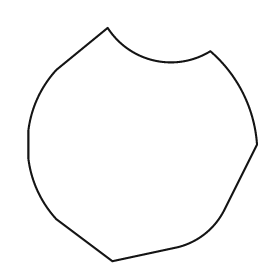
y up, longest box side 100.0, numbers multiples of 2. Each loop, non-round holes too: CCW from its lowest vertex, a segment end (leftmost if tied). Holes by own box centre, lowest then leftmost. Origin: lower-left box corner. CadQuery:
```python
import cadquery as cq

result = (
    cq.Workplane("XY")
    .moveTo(36.0, 0.0)
    .lineTo(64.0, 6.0)
    .threePointArc((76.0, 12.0), (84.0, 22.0))
    .lineTo(98.0, 50.0)
    .threePointArc((92.0, 72.0), (78.0, 90.0))
    .threePointArc((54.0, 86.0), (34.0, 100.0))
    .lineTo(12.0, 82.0)
    .threePointArc((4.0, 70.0), (0.0, 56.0))
    .lineTo(0.0, 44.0)
    .threePointArc((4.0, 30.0), (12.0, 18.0))
    .close()
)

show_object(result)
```